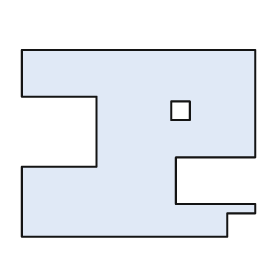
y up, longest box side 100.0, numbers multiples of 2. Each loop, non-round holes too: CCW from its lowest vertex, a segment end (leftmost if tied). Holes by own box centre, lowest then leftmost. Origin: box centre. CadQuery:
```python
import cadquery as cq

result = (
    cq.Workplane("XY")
    .moveTo(-50.0, -40.0)
    .lineTo(38.0, -40.0)
    .lineTo(38.0, -30.0)
    .lineTo(50.0, -30.0)
    .lineTo(50.0, -26.0)
    .lineTo(16.0, -26.0)
    .lineTo(16.0, -6.0)
    .lineTo(50.0, -6.0)
    .lineTo(50.0, 40.0)
    .lineTo(-50.0, 40.0)
    .lineTo(-50.0, 20.0)
    .lineTo(-18.0, 20.0)
    .lineTo(-18.0, -10.0)
    .lineTo(-50.0, -10.0)
    .close()
    .moveTo(14.0, 10.0)
    .lineTo(22.0, 10.0)
    .lineTo(22.0, 18.0)
    .lineTo(14.0, 18.0)
    .close()
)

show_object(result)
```